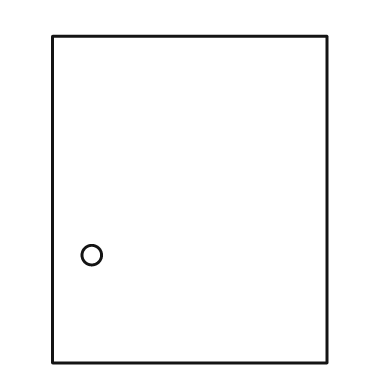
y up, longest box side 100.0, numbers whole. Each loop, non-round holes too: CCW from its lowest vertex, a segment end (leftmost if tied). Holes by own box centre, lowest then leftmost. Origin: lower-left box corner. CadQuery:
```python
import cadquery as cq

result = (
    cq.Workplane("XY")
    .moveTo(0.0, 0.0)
    .lineTo(84.0, 0.0)
    .lineTo(84.0, 100.0)
    .lineTo(0.0, 100.0)
    .close()
    .moveTo(12.0, 33.0)
    .circle(3.0)
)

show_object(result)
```